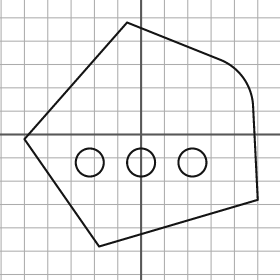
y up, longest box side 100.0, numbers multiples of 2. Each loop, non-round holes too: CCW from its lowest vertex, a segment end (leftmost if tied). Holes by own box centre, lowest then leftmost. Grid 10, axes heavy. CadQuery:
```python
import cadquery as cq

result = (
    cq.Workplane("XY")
    .moveTo(-18.0, -48.0)
    .lineTo(50.0, -28.0)
    .lineTo(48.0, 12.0)
    .threePointArc((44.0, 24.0), (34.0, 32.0))
    .lineTo(-6.0, 48.0)
    .lineTo(-50.0, -2.0)
    .close()
    .moveTo(-22.0, -12.0)
    .circle(6.0)
    .moveTo(0.0, -12.0)
    .circle(6.0)
    .moveTo(22.0, -12.0)
    .circle(6.0)
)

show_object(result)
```